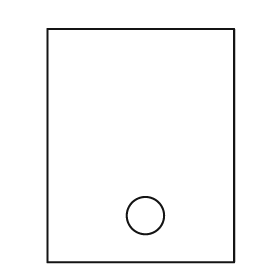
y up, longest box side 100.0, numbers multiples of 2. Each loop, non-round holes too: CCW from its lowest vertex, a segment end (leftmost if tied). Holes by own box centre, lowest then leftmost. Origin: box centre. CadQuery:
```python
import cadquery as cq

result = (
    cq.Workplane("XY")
    .moveTo(-40.0, -50.0)
    .lineTo(40.0, -50.0)
    .lineTo(40.0, 50.0)
    .lineTo(-40.0, 50.0)
    .close()
    .moveTo(2.0, -30.0)
    .circle(8.0)
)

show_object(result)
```